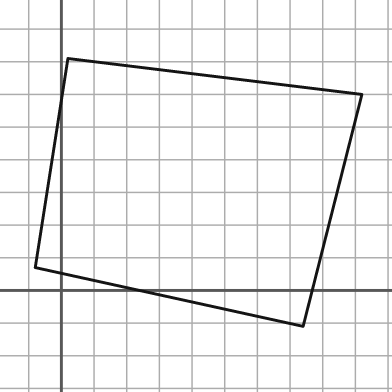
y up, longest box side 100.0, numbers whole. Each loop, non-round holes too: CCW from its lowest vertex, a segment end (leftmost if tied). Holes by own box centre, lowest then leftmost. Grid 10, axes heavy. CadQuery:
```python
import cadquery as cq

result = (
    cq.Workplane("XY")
    .moveTo(74.0, -11.0)
    .lineTo(92.0, 60.0)
    .lineTo(2.0, 71.0)
    .lineTo(-8.0, 7.0)
    .close()
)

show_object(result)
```